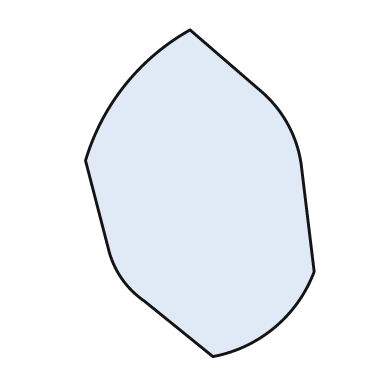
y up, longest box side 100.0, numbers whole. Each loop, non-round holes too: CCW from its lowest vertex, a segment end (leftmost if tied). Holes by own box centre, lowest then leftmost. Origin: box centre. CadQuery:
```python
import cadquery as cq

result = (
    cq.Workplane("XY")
    .moveTo(4.0, -50.0)
    .threePointArc((23.0, -41.0), (35.0, -24.0))
    .lineTo(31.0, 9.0)
    .threePointArc((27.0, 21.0), (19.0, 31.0))
    .lineTo(-3.0, 50.0)
    .threePointArc((-23.0, 33.0), (-35.0, 10.0))
    .lineTo(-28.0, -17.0)
    .threePointArc((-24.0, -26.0), (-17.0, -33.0))
    .close()
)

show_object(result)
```